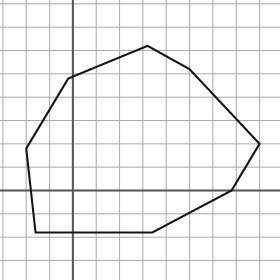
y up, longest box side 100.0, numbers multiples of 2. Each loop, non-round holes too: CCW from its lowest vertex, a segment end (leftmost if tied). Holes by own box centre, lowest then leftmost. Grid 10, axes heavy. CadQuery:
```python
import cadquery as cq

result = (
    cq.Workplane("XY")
    .moveTo(-16.0, -18.0)
    .lineTo(34.0, -18.0)
    .lineTo(68.0, 0.0)
    .lineTo(80.0, 20.0)
    .lineTo(50.0, 52.0)
    .lineTo(32.0, 62.0)
    .lineTo(-2.0, 48.0)
    .lineTo(-20.0, 18.0)
    .close()
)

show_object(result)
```